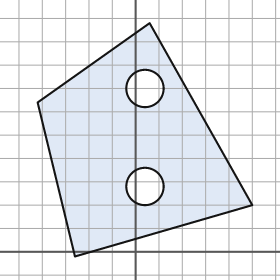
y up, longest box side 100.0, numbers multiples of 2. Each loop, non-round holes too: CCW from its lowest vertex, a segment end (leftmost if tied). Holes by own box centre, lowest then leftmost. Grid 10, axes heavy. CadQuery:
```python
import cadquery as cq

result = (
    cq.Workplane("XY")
    .moveTo(-26.0, -2.0)
    .lineTo(50.0, 20.0)
    .lineTo(6.0, 98.0)
    .lineTo(-42.0, 64.0)
    .close()
    .moveTo(4.0, 28.0)
    .circle(8.0)
    .moveTo(4.0, 70.0)
    .circle(8.0)
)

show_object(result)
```